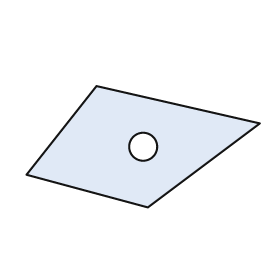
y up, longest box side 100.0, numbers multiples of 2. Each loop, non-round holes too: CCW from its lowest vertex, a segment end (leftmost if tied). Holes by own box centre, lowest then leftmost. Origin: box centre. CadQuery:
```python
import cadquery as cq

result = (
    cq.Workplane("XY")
    .moveTo(2.0, -26.0)
    .lineTo(50.0, 10.0)
    .lineTo(-20.0, 26.0)
    .lineTo(-50.0, -12.0)
    .close()
    .moveTo(0.0, 0.0)
    .circle(6.0)
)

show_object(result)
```